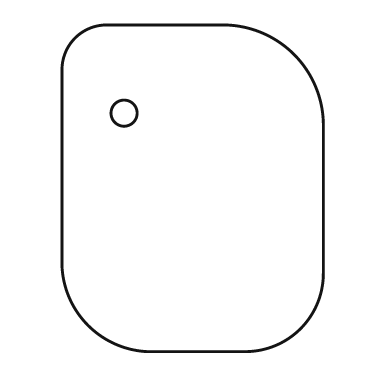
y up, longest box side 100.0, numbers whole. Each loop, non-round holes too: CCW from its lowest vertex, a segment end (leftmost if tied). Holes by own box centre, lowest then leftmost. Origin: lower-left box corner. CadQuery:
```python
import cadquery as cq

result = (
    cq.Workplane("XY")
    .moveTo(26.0, 0.0)
    .lineTo(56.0, 0.0)
    .threePointArc((73.0, 7.0), (80.0, 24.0))
    .lineTo(80.0, 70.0)
    .threePointArc((71.0, 91.0), (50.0, 100.0))
    .lineTo(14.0, 100.0)
    .threePointArc((4.0, 96.0), (0.0, 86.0))
    .lineTo(0.0, 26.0)
    .threePointArc((8.0, 8.0), (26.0, 0.0))
    .close()
    .moveTo(19.0, 73.0)
    .circle(4.0)
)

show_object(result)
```